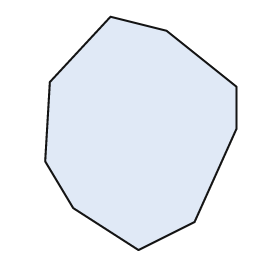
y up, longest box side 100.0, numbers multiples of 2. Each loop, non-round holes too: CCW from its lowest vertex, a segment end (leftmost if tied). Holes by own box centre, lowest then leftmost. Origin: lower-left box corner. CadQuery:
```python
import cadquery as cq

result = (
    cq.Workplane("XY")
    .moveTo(40.0, 0.0)
    .lineTo(64.0, 12.0)
    .lineTo(82.0, 52.0)
    .lineTo(82.0, 70.0)
    .lineTo(52.0, 94.0)
    .lineTo(28.0, 100.0)
    .lineTo(2.0, 72.0)
    .lineTo(0.0, 38.0)
    .lineTo(12.0, 18.0)
    .close()
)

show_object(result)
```